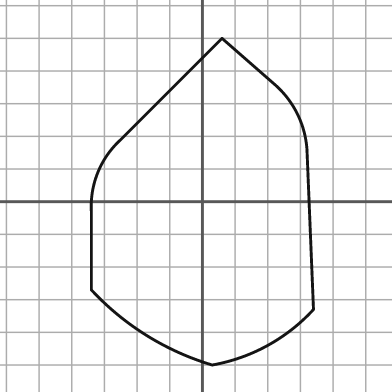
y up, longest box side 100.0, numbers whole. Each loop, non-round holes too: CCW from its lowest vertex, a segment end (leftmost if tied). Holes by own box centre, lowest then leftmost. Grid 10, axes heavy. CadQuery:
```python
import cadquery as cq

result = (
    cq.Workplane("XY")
    .moveTo(3.0, -50.0)
    .threePointArc((20.0, -44.0), (34.0, -33.0))
    .lineTo(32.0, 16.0)
    .threePointArc((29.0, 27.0), (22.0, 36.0))
    .lineTo(6.0, 50.0)
    .lineTo(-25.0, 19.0)
    .threePointArc((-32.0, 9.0), (-34.0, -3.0))
    .lineTo(-34.0, -27.0)
    .threePointArc((-17.0, -41.0), (3.0, -50.0))
    .close()
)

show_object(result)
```